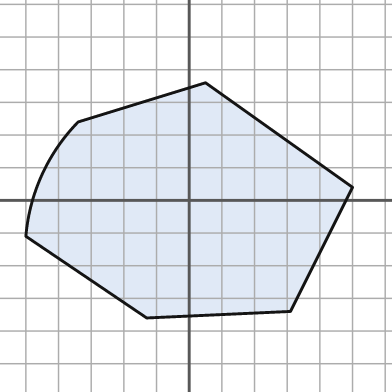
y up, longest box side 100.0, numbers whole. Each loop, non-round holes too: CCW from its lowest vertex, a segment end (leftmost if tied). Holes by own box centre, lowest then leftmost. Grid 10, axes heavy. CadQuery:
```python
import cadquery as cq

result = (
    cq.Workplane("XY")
    .moveTo(-13.0, -36.0)
    .lineTo(31.0, -34.0)
    .lineTo(50.0, 4.0)
    .lineTo(5.0, 36.0)
    .lineTo(-34.0, 24.0)
    .threePointArc((-45.0, 8.0), (-50.0, -11.0))
    .close()
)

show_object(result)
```